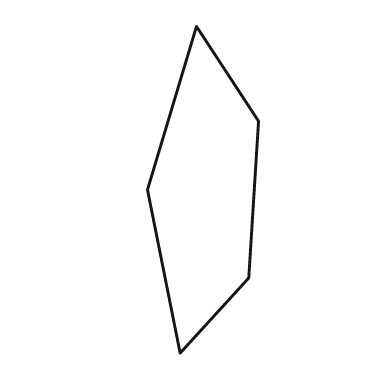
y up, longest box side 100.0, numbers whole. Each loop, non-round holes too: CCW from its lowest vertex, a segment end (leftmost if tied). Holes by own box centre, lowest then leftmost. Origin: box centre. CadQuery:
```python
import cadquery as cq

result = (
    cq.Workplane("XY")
    .moveTo(-7.0, -50.0)
    .lineTo(14.0, -27.0)
    .lineTo(17.0, 21.0)
    .lineTo(-2.0, 50.0)
    .lineTo(-17.0, 0.0)
    .close()
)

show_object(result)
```